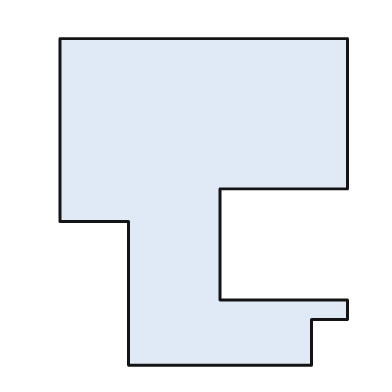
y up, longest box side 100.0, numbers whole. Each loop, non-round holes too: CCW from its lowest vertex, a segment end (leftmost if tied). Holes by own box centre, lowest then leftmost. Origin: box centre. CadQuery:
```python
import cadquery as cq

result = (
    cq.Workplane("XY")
    .moveTo(-23.0, -50.0)
    .lineTo(33.0, -50.0)
    .lineTo(33.0, -36.0)
    .lineTo(44.0, -36.0)
    .lineTo(44.0, -30.0)
    .lineTo(5.0, -30.0)
    .lineTo(5.0, 4.0)
    .lineTo(44.0, 4.0)
    .lineTo(44.0, 50.0)
    .lineTo(-44.0, 50.0)
    .lineTo(-44.0, -6.0)
    .lineTo(-23.0, -6.0)
    .close()
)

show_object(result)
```